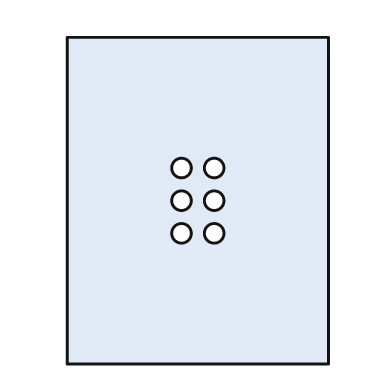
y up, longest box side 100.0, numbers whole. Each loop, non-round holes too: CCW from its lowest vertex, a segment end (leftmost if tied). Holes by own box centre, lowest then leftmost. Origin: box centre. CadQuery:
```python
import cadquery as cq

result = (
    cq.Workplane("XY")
    .moveTo(-40.0, -50.0)
    .lineTo(40.0, -50.0)
    .lineTo(40.0, 50.0)
    .lineTo(-40.0, 50.0)
    .close()
    .moveTo(-5.0, -10.0)
    .circle(3.0)
    .moveTo(5.0, -10.0)
    .circle(3.0)
    .moveTo(-5.0, 0.0)
    .circle(3.0)
    .moveTo(5.0, 0.0)
    .circle(3.0)
    .moveTo(-5.0, 10.0)
    .circle(3.0)
    .moveTo(5.0, 10.0)
    .circle(3.0)
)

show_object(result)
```